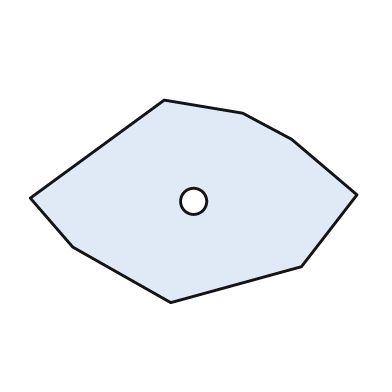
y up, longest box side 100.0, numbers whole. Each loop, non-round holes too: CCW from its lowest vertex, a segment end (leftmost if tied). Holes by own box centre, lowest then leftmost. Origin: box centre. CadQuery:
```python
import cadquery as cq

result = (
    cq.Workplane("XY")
    .moveTo(-7.0, -31.0)
    .lineTo(33.0, -20.0)
    .lineTo(50.0, 2.0)
    .lineTo(30.0, 19.0)
    .lineTo(15.0, 27.0)
    .lineTo(-9.0, 31.0)
    .lineTo(-50.0, 1.0)
    .lineTo(-37.0, -14.0)
    .close()
    .moveTo(0.0, 0.0)
    .circle(4.0)
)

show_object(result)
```